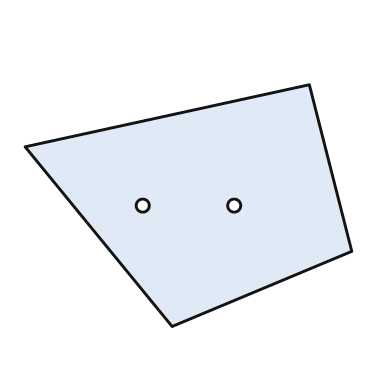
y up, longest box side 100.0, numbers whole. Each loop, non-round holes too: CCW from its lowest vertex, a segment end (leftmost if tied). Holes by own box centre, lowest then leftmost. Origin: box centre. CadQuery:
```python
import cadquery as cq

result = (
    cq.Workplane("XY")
    .moveTo(-5.0, -37.0)
    .lineTo(50.0, -14.0)
    .lineTo(37.0, 37.0)
    .lineTo(-50.0, 18.0)
    .close()
    .moveTo(-14.0, 0.0)
    .circle(2.0)
    .moveTo(14.0, 0.0)
    .circle(2.0)
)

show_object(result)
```